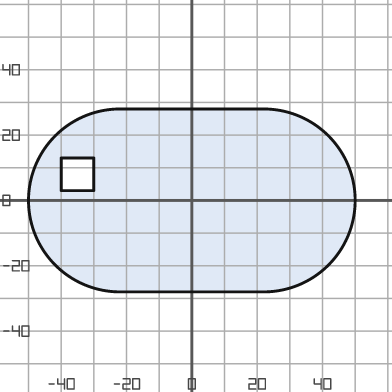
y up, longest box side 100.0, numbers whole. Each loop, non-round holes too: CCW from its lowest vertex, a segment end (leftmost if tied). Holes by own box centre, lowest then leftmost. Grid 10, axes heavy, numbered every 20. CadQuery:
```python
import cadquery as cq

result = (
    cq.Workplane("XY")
    .moveTo(-22.0, -28.0)
    .lineTo(22.0, -28.0)
    .threePointArc((50.0, 0.0), (22.0, 28.0))
    .lineTo(-22.0, 28.0)
    .threePointArc((-50.0, 0.0), (-22.0, -28.0))
    .close()
    .moveTo(-40.0, 3.0)
    .lineTo(-30.0, 3.0)
    .lineTo(-30.0, 13.0)
    .lineTo(-40.0, 13.0)
    .close()
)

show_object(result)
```